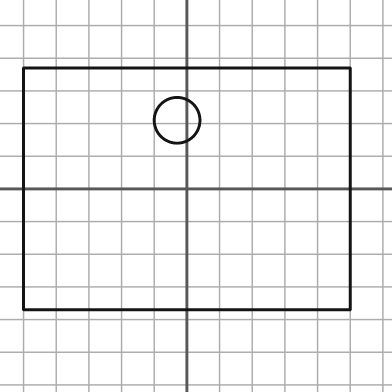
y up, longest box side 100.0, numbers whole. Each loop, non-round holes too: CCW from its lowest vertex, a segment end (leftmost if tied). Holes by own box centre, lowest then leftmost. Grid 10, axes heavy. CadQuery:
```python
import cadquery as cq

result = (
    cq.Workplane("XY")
    .moveTo(-50.0, -37.0)
    .lineTo(50.0, -37.0)
    .lineTo(50.0, 37.0)
    .lineTo(-50.0, 37.0)
    .close()
    .moveTo(-3.0, 21.0)
    .circle(7.0)
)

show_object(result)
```